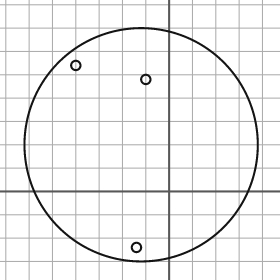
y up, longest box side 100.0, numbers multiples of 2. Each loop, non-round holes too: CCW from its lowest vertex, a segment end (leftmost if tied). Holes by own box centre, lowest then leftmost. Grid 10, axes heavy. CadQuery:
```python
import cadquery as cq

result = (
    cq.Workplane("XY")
    .moveTo(-12.0, 20.0)
    .circle(50.0)
    .moveTo(-14.0, -24.0)
    .circle(2.0)
    .moveTo(-10.0, 48.0)
    .circle(2.0)
    .moveTo(-40.0, 54.0)
    .circle(2.0)
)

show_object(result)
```